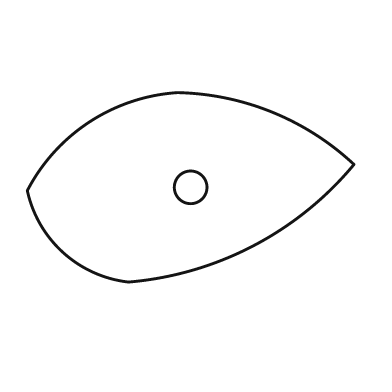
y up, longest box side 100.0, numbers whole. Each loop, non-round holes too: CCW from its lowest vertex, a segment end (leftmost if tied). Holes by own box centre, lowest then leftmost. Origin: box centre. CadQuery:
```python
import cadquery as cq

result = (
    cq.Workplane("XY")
    .moveTo(-19.0, -29.0)
    .threePointArc((19.0, -18.0), (50.0, 7.0))
    .threePointArc((25.0, 23.0), (-4.0, 29.0))
    .threePointArc((-31.0, 20.0), (-50.0, -1.0))
    .threePointArc((-39.0, -20.0), (-19.0, -29.0))
    .close()
    .moveTo(0.0, 0.0)
    .circle(5.0)
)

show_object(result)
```